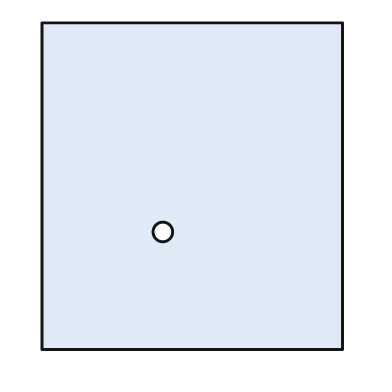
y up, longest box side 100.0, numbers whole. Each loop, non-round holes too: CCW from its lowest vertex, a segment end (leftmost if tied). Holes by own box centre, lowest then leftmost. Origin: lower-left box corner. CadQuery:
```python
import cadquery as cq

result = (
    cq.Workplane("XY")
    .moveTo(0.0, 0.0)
    .lineTo(92.0, 0.0)
    .lineTo(92.0, 100.0)
    .lineTo(0.0, 100.0)
    .close()
    .moveTo(37.0, 36.0)
    .circle(3.0)
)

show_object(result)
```